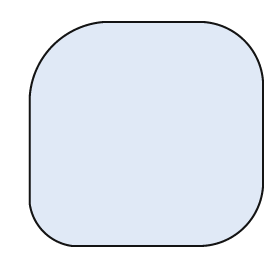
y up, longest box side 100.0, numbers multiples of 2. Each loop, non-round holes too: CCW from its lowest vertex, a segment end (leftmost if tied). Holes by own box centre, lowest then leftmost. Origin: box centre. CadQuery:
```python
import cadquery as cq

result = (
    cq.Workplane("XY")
    .moveTo(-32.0, -48.0)
    .lineTo(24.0, -48.0)
    .threePointArc((42.0, -40.0), (50.0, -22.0))
    .lineTo(50.0, 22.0)
    .threePointArc((42.0, 40.0), (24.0, 48.0))
    .lineTo(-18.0, 48.0)
    .threePointArc((-40.0, 38.0), (-50.0, 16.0))
    .lineTo(-50.0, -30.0)
    .threePointArc((-44.0, -42.0), (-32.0, -48.0))
    .close()
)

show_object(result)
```